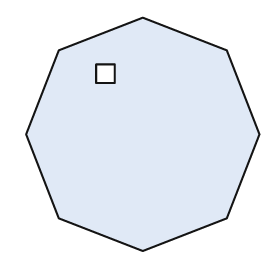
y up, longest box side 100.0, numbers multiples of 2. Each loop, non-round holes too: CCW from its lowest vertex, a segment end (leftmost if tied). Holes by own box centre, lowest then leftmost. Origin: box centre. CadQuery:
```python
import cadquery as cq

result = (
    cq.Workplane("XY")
    .moveTo(0.0, -50.0)
    .lineTo(36.0, -36.0)
    .lineTo(50.0, 0.0)
    .lineTo(36.0, 36.0)
    .lineTo(0.0, 50.0)
    .lineTo(-36.0, 36.0)
    .lineTo(-50.0, 0.0)
    .lineTo(-36.0, -36.0)
    .close()
    .moveTo(-20.0, 22.0)
    .lineTo(-12.0, 22.0)
    .lineTo(-12.0, 30.0)
    .lineTo(-20.0, 30.0)
    .close()
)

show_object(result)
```